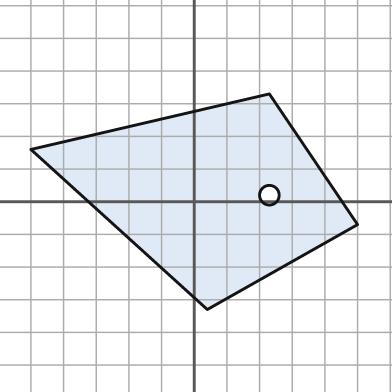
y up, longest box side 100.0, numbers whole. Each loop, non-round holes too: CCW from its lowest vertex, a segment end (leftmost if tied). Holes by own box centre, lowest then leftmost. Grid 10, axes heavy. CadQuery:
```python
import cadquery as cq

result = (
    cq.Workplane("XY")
    .moveTo(4.0, -33.0)
    .lineTo(50.0, -7.0)
    .lineTo(23.0, 33.0)
    .lineTo(-50.0, 16.0)
    .close()
    .moveTo(23.0, 2.0)
    .circle(3.0)
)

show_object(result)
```